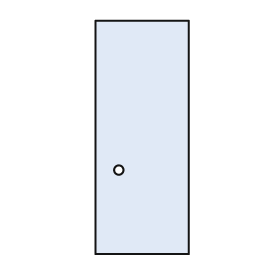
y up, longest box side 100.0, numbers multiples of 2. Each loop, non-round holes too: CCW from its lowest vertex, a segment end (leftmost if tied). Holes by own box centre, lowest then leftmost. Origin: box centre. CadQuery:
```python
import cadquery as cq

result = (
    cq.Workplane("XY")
    .moveTo(-20.0, -50.0)
    .lineTo(20.0, -50.0)
    .lineTo(20.0, 50.0)
    .lineTo(-20.0, 50.0)
    .close()
    .moveTo(-10.0, -14.0)
    .circle(2.0)
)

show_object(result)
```